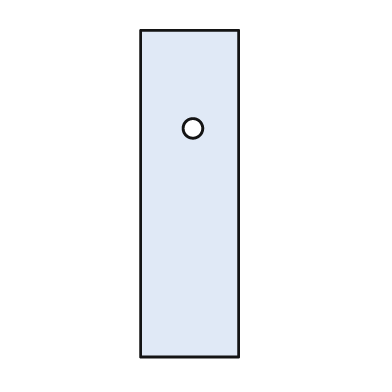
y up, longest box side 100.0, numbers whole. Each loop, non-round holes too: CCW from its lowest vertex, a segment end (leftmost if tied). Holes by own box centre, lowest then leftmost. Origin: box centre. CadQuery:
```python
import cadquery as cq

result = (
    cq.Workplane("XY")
    .moveTo(-15.0, -50.0)
    .lineTo(15.0, -50.0)
    .lineTo(15.0, 50.0)
    .lineTo(-15.0, 50.0)
    .close()
    .moveTo(1.0, 20.0)
    .circle(3.0)
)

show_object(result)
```